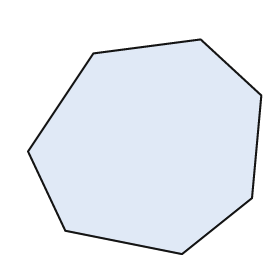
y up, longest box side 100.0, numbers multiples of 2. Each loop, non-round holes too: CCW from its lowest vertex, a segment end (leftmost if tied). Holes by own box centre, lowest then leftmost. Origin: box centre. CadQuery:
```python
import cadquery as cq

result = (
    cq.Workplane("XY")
    .moveTo(16.0, -46.0)
    .lineTo(46.0, -22.0)
    .lineTo(50.0, 22.0)
    .lineTo(24.0, 46.0)
    .lineTo(-22.0, 40.0)
    .lineTo(-50.0, -2.0)
    .lineTo(-34.0, -36.0)
    .close()
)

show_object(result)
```